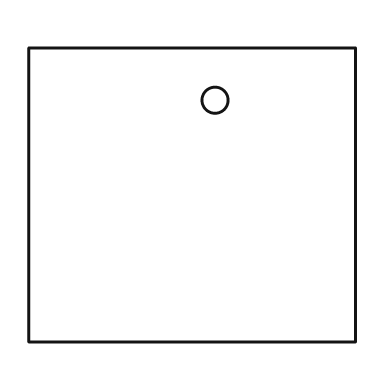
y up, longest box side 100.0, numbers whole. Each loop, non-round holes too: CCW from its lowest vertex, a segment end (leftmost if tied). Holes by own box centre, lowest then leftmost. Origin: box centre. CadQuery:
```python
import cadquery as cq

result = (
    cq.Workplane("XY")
    .moveTo(-50.0, -45.0)
    .lineTo(50.0, -45.0)
    .lineTo(50.0, 45.0)
    .lineTo(-50.0, 45.0)
    .close()
    .moveTo(7.0, 29.0)
    .circle(4.0)
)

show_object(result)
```